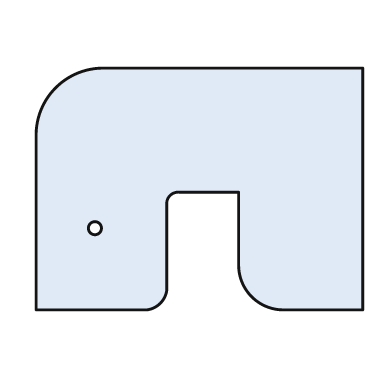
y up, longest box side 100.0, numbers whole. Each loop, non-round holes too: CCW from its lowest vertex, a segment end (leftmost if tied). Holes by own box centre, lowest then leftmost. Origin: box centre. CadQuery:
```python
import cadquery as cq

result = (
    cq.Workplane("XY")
    .moveTo(-50.0, -37.0)
    .lineTo(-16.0, -37.0)
    .threePointArc((-12.0, -35.0), (-10.0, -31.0))
    .lineTo(-10.0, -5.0)
    .threePointArc((-9.0, -2.0), (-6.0, -1.0))
    .lineTo(12.0, -1.0)
    .lineTo(12.0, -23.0)
    .threePointArc((16.0, -33.0), (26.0, -37.0))
    .lineTo(50.0, -37.0)
    .lineTo(50.0, 37.0)
    .lineTo(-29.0, 37.0)
    .threePointArc((-44.0, 31.0), (-50.0, 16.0))
    .close()
    .moveTo(-32.0, -12.0)
    .circle(2.0)
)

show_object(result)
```